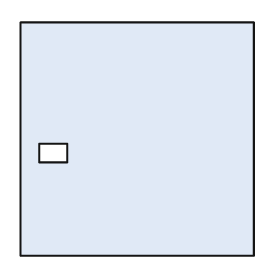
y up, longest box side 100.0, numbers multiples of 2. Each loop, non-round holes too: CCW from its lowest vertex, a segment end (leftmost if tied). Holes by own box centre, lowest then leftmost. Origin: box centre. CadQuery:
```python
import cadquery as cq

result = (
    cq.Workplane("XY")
    .moveTo(-50.0, -50.0)
    .lineTo(50.0, -50.0)
    .lineTo(50.0, 50.0)
    .lineTo(-50.0, 50.0)
    .close()
    .moveTo(-42.0, -10.0)
    .lineTo(-30.0, -10.0)
    .lineTo(-30.0, -2.0)
    .lineTo(-42.0, -2.0)
    .close()
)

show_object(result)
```